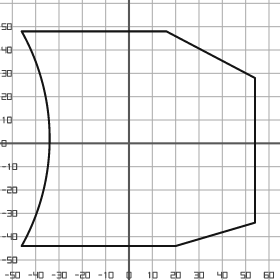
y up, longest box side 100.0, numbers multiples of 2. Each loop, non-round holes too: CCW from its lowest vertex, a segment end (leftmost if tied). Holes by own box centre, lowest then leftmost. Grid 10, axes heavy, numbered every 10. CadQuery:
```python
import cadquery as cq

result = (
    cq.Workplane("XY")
    .moveTo(-46.0, -44.0)
    .lineTo(20.0, -44.0)
    .lineTo(54.0, -34.0)
    .lineTo(54.0, 28.0)
    .lineTo(16.0, 48.0)
    .lineTo(-46.0, 48.0)
    .threePointArc((-34.0, 2.0), (-46.0, -44.0))
    .close()
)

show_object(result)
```